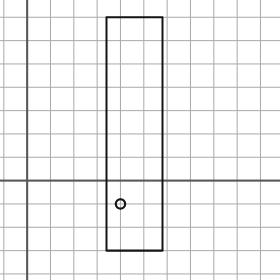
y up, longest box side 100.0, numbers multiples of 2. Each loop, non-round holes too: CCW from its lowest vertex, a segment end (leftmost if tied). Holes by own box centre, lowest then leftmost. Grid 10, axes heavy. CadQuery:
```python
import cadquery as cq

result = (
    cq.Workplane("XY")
    .moveTo(34.0, -30.0)
    .lineTo(58.0, -30.0)
    .lineTo(58.0, 70.0)
    .lineTo(34.0, 70.0)
    .close()
    .moveTo(40.0, -10.0)
    .circle(2.0)
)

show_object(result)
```